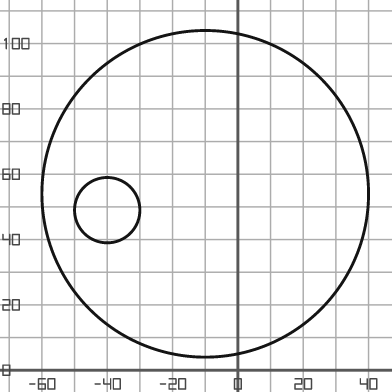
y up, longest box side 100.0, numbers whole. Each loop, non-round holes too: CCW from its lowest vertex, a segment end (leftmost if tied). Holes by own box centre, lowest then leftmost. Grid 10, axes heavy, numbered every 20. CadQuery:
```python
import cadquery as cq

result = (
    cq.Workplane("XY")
    .moveTo(-10.0, 54.0)
    .circle(50.0)
    .moveTo(-40.0, 49.0)
    .circle(10.0)
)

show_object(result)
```